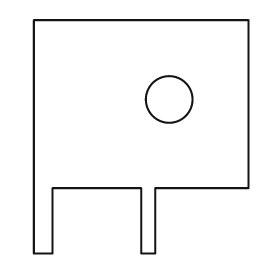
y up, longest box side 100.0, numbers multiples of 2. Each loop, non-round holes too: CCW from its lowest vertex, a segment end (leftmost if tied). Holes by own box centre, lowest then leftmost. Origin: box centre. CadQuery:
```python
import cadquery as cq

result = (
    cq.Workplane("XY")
    .moveTo(-46.0, -50.0)
    .lineTo(-38.0, -50.0)
    .lineTo(-38.0, -22.0)
    .lineTo(0.0, -22.0)
    .lineTo(0.0, -50.0)
    .lineTo(6.0, -50.0)
    .lineTo(6.0, -22.0)
    .lineTo(46.0, -22.0)
    .lineTo(46.0, 50.0)
    .lineTo(-46.0, 50.0)
    .close()
    .moveTo(12.0, 16.0)
    .circle(10.0)
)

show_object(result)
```